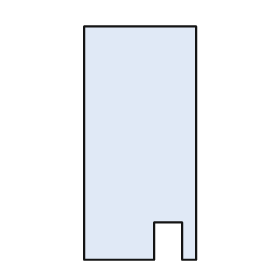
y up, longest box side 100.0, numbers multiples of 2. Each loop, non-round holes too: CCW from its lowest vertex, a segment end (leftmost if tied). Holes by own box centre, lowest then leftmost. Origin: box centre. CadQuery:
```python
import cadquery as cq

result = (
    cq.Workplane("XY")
    .moveTo(-24.0, -50.0)
    .lineTo(6.0, -50.0)
    .lineTo(6.0, -34.0)
    .lineTo(18.0, -34.0)
    .lineTo(18.0, -50.0)
    .lineTo(24.0, -50.0)
    .lineTo(24.0, 50.0)
    .lineTo(-24.0, 50.0)
    .close()
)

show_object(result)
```